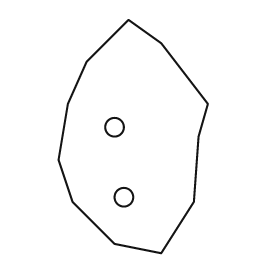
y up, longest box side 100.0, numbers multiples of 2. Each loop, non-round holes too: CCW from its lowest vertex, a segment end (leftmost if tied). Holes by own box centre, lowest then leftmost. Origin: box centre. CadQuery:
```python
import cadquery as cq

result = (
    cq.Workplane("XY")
    .moveTo(12.0, -50.0)
    .lineTo(26.0, -28.0)
    .lineTo(28.0, 0.0)
    .lineTo(32.0, 14.0)
    .lineTo(12.0, 40.0)
    .lineTo(-2.0, 50.0)
    .lineTo(-20.0, 32.0)
    .lineTo(-28.0, 14.0)
    .lineTo(-32.0, -10.0)
    .lineTo(-26.0, -28.0)
    .lineTo(-8.0, -46.0)
    .close()
    .moveTo(-4.0, -26.0)
    .circle(4.0)
    .moveTo(-8.0, 4.0)
    .circle(4.0)
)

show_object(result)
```